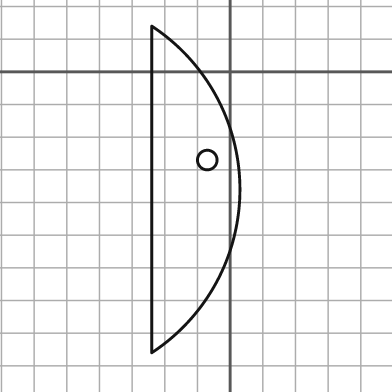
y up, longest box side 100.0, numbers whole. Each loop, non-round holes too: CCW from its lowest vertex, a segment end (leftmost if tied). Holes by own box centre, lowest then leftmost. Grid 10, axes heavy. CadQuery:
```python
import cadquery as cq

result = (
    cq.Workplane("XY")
    .moveTo(-24.0, -86.0)
    .threePointArc((3.0, -36.0), (-24.0, 14.0))
    .close()
    .moveTo(-7.0, -27.0)
    .circle(3.0)
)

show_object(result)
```